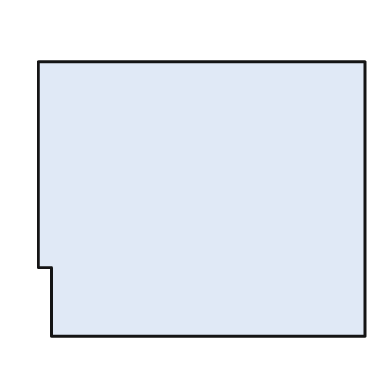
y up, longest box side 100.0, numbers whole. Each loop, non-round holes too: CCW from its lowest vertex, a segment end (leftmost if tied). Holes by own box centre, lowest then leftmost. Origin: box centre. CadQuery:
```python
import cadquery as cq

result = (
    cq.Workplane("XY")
    .moveTo(-46.0, -42.0)
    .lineTo(50.0, -42.0)
    .lineTo(50.0, 42.0)
    .lineTo(-50.0, 42.0)
    .lineTo(-50.0, -21.0)
    .lineTo(-46.0, -21.0)
    .close()
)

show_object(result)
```